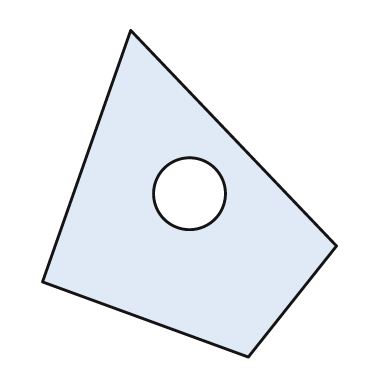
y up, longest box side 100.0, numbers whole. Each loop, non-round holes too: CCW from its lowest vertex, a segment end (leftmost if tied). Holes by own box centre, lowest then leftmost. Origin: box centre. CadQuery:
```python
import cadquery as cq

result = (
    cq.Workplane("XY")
    .moveTo(18.0, -50.0)
    .lineTo(45.0, -16.0)
    .lineTo(-18.0, 50.0)
    .lineTo(-45.0, -27.0)
    .close()
    .moveTo(0.0, 0.0)
    .circle(11.0)
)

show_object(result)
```